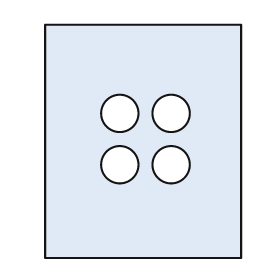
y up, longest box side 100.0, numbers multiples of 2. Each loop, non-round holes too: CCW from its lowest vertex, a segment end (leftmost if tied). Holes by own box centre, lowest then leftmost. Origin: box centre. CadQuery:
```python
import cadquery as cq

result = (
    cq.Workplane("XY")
    .moveTo(-42.0, -50.0)
    .lineTo(42.0, -50.0)
    .lineTo(42.0, 50.0)
    .lineTo(-42.0, 50.0)
    .close()
    .moveTo(-10.0, -10.0)
    .circle(8.0)
    .moveTo(12.0, -10.0)
    .circle(8.0)
    .moveTo(-10.0, 12.0)
    .circle(8.0)
    .moveTo(12.0, 12.0)
    .circle(8.0)
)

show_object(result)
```